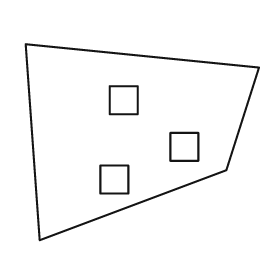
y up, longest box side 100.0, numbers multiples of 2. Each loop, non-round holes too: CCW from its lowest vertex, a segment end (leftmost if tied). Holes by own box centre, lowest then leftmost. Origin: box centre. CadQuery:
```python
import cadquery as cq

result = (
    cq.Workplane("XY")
    .moveTo(-44.0, -42.0)
    .lineTo(36.0, -12.0)
    .lineTo(50.0, 32.0)
    .lineTo(-50.0, 42.0)
    .close()
    .moveTo(-18.0, -22.0)
    .lineTo(-6.0, -22.0)
    .lineTo(-6.0, -10.0)
    .lineTo(-18.0, -10.0)
    .close()
    .moveTo(12.0, -8.0)
    .lineTo(24.0, -8.0)
    .lineTo(24.0, 4.0)
    .lineTo(12.0, 4.0)
    .close()
    .moveTo(-14.0, 12.0)
    .lineTo(-2.0, 12.0)
    .lineTo(-2.0, 24.0)
    .lineTo(-14.0, 24.0)
    .close()
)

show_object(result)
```